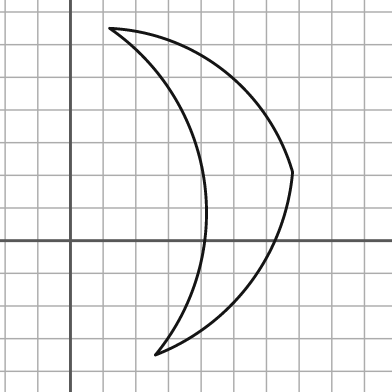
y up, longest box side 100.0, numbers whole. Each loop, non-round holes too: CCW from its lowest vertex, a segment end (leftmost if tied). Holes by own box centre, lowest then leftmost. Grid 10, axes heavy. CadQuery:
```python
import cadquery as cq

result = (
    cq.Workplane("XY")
    .moveTo(26.0, -35.0)
    .threePointArc((55.0, -13.0), (68.0, 21.0))
    .threePointArc((47.0, 52.0), (12.0, 65.0))
    .threePointArc((41.0, 18.0), (26.0, -35.0))
    .close()
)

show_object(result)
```